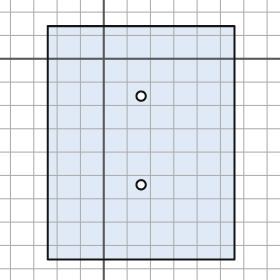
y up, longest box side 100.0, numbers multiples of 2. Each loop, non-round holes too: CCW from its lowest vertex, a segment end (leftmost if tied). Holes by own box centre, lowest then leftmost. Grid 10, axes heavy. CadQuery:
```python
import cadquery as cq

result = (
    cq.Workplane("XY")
    .moveTo(-24.0, -86.0)
    .lineTo(56.0, -86.0)
    .lineTo(56.0, 14.0)
    .lineTo(-24.0, 14.0)
    .close()
    .moveTo(16.0, -54.0)
    .circle(2.0)
    .moveTo(16.0, -16.0)
    .circle(2.0)
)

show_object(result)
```